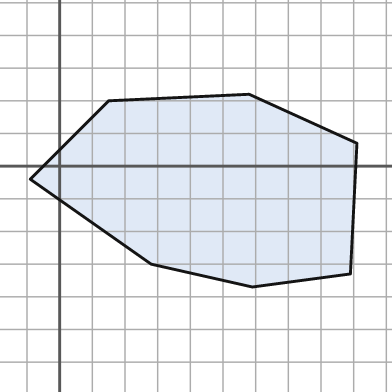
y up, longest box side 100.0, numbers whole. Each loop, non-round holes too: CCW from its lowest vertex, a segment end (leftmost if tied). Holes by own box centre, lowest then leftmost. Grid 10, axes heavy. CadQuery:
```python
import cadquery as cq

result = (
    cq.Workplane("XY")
    .moveTo(59.0, -37.0)
    .lineTo(89.0, -33.0)
    .lineTo(91.0, 7.0)
    .lineTo(58.0, 22.0)
    .lineTo(15.0, 20.0)
    .lineTo(-9.0, -4.0)
    .lineTo(28.0, -30.0)
    .close()
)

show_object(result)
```